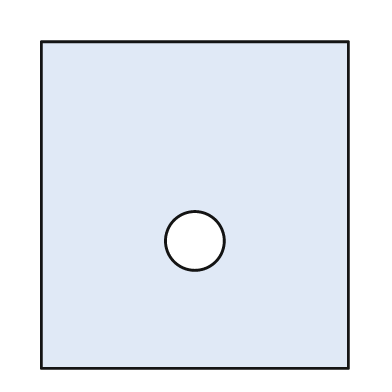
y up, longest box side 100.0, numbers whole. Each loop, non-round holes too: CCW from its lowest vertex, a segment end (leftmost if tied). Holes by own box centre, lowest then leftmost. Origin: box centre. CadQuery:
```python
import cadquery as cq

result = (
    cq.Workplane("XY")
    .moveTo(-47.0, -50.0)
    .lineTo(47.0, -50.0)
    .lineTo(47.0, 50.0)
    .lineTo(-47.0, 50.0)
    .close()
    .moveTo(0.0, -11.0)
    .circle(9.0)
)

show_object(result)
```